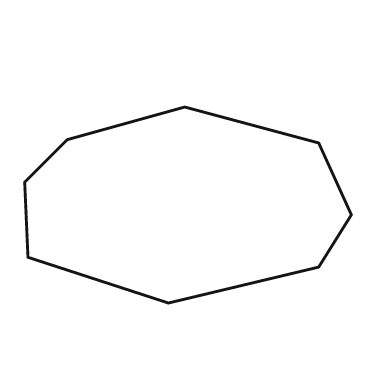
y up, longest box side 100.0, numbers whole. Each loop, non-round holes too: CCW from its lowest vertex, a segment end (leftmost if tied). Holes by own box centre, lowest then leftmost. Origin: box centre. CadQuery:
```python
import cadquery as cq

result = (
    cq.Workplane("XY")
    .moveTo(-6.0, -30.0)
    .lineTo(40.0, -19.0)
    .lineTo(50.0, -3.0)
    .lineTo(40.0, 19.0)
    .lineTo(-1.0, 30.0)
    .lineTo(-37.0, 20.0)
    .lineTo(-50.0, 7.0)
    .lineTo(-49.0, -16.0)
    .close()
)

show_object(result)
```